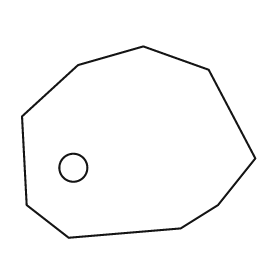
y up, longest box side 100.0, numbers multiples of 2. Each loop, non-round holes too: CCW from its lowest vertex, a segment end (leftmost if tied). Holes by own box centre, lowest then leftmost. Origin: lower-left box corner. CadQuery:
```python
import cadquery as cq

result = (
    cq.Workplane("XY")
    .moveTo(20.0, 0.0)
    .lineTo(68.0, 4.0)
    .lineTo(84.0, 14.0)
    .lineTo(100.0, 34.0)
    .lineTo(80.0, 72.0)
    .lineTo(52.0, 82.0)
    .lineTo(24.0, 74.0)
    .lineTo(0.0, 52.0)
    .lineTo(2.0, 14.0)
    .close()
    .moveTo(22.0, 30.0)
    .circle(6.0)
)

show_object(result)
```